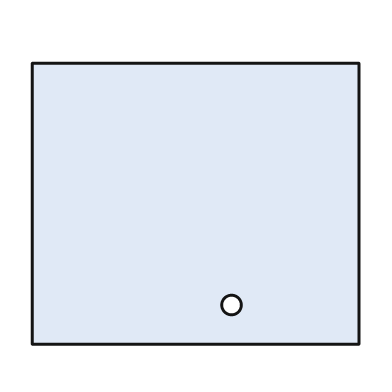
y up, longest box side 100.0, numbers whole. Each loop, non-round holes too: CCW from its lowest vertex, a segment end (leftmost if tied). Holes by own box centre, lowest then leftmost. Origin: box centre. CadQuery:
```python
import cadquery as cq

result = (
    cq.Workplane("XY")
    .moveTo(-50.0, -43.0)
    .lineTo(50.0, -43.0)
    .lineTo(50.0, 43.0)
    .lineTo(-50.0, 43.0)
    .close()
    .moveTo(11.0, -31.0)
    .circle(3.0)
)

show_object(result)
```